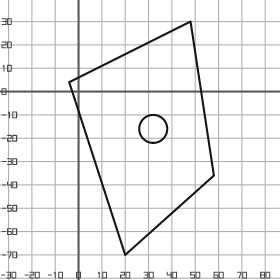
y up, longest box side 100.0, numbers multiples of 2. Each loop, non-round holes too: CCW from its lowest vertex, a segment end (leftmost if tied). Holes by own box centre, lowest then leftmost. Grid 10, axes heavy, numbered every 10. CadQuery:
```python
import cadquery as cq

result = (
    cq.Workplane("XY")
    .moveTo(20.0, -70.0)
    .lineTo(58.0, -36.0)
    .lineTo(48.0, 30.0)
    .lineTo(-4.0, 4.0)
    .close()
    .moveTo(32.0, -16.0)
    .circle(6.0)
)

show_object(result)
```